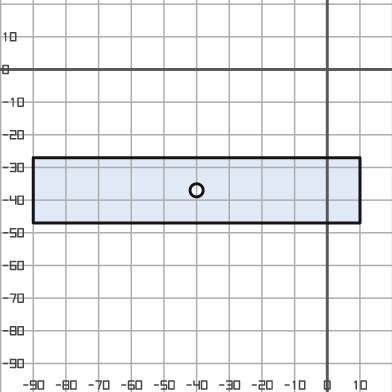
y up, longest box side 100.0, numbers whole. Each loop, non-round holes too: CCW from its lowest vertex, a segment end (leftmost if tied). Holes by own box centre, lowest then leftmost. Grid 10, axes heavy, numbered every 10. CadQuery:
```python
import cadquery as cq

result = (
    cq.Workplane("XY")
    .moveTo(-90.0, -47.0)
    .lineTo(10.0, -47.0)
    .lineTo(10.0, -27.0)
    .lineTo(-90.0, -27.0)
    .close()
    .moveTo(-40.0, -37.0)
    .circle(2.0)
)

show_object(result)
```